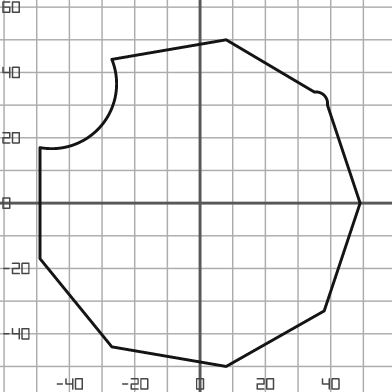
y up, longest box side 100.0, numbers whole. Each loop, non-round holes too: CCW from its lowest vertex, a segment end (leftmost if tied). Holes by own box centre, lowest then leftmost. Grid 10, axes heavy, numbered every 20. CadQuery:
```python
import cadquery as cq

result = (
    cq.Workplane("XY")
    .moveTo(8.0, -50.0)
    .lineTo(38.0, -33.0)
    .lineTo(49.0, 0.0)
    .lineTo(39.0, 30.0)
    .threePointArc((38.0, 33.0), (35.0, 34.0))
    .lineTo(8.0, 50.0)
    .lineTo(-27.0, 44.0)
    .threePointArc((-30.0, 24.0), (-49.0, 17.0))
    .lineTo(-49.0, -17.0)
    .lineTo(-27.0, -44.0)
    .close()
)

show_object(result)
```